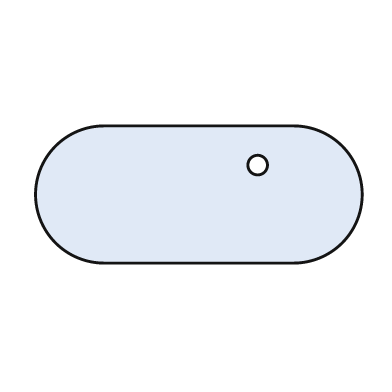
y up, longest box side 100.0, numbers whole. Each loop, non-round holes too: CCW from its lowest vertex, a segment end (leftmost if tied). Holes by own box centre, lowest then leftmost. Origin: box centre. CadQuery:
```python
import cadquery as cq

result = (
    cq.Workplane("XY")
    .moveTo(-29.0, -21.0)
    .lineTo(29.0, -21.0)
    .threePointArc((50.0, 0.0), (29.0, 21.0))
    .lineTo(-29.0, 21.0)
    .threePointArc((-50.0, 0.0), (-29.0, -21.0))
    .close()
    .moveTo(18.0, 9.0)
    .circle(3.0)
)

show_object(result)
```